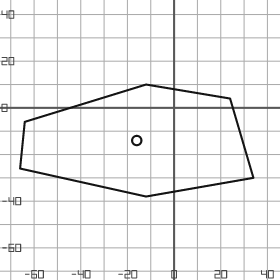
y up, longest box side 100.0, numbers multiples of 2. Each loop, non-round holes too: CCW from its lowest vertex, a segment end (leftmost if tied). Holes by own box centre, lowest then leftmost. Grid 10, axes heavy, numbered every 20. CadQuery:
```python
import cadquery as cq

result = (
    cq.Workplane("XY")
    .moveTo(-12.0, -38.0)
    .lineTo(34.0, -30.0)
    .lineTo(24.0, 4.0)
    .lineTo(-12.0, 10.0)
    .lineTo(-64.0, -6.0)
    .lineTo(-66.0, -26.0)
    .close()
    .moveTo(-16.0, -14.0)
    .circle(2.0)
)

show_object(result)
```